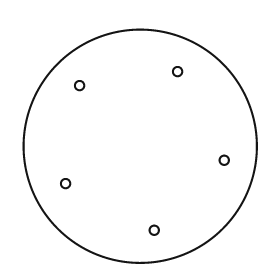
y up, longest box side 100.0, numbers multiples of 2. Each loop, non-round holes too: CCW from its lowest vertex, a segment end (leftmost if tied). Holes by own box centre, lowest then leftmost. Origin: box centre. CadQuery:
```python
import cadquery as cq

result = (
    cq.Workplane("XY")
    .moveTo(0.0, 0.0)
    .circle(50.0)
    .moveTo(6.0, -36.0)
    .circle(2.0)
    .moveTo(-32.0, -16.0)
    .circle(2.0)
    .moveTo(36.0, -6.0)
    .circle(2.0)
    .moveTo(-26.0, 26.0)
    .circle(2.0)
    .moveTo(16.0, 32.0)
    .circle(2.0)
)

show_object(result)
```